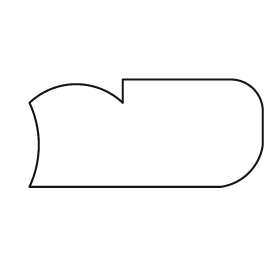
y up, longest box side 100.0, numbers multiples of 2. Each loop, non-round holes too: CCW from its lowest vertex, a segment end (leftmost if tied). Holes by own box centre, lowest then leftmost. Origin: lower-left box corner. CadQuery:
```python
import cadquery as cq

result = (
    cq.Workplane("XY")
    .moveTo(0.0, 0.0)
    .lineTo(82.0, 0.0)
    .threePointArc((94.0, 6.0), (100.0, 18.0))
    .lineTo(100.0, 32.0)
    .threePointArc((96.0, 42.0), (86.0, 46.0))
    .lineTo(40.0, 46.0)
    .lineTo(40.0, 36.0)
    .threePointArc((20.0, 44.0), (0.0, 36.0))
    .threePointArc((4.0, 18.0), (0.0, 0.0))
    .close()
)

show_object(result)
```